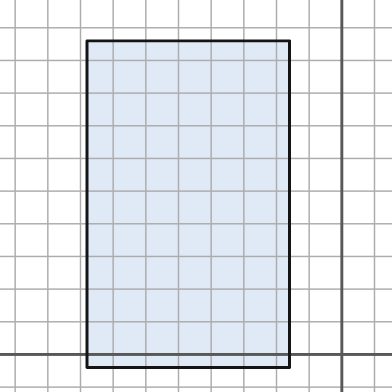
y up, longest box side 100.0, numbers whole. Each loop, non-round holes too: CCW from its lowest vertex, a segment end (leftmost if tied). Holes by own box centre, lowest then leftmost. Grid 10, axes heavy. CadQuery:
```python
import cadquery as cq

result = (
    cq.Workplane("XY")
    .moveTo(-78.0, -4.0)
    .lineTo(-16.0, -4.0)
    .lineTo(-16.0, 96.0)
    .lineTo(-78.0, 96.0)
    .close()
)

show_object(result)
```